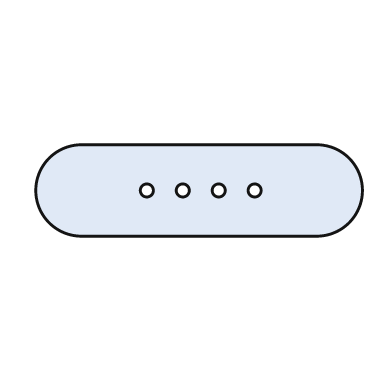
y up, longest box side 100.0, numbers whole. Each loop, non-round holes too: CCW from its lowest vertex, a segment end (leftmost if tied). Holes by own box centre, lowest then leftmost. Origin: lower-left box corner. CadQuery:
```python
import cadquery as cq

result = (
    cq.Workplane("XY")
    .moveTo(14.0, 0.0)
    .lineTo(86.0, 0.0)
    .threePointArc((100.0, 14.0), (86.0, 28.0))
    .lineTo(14.0, 28.0)
    .threePointArc((0.0, 14.0), (14.0, 0.0))
    .close()
    .moveTo(34.0, 14.0)
    .circle(2.0)
    .moveTo(45.0, 14.0)
    .circle(2.0)
    .moveTo(56.0, 14.0)
    .circle(2.0)
    .moveTo(67.0, 14.0)
    .circle(2.0)
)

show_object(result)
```